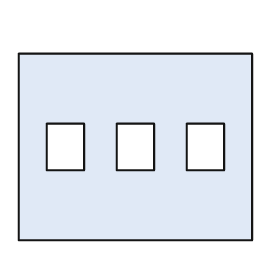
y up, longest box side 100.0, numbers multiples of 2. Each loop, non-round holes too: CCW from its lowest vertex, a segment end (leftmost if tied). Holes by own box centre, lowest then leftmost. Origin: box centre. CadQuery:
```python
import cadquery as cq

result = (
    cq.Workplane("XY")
    .moveTo(-50.0, -40.0)
    .lineTo(50.0, -40.0)
    .lineTo(50.0, 40.0)
    .lineTo(-50.0, 40.0)
    .close()
    .moveTo(-38.0, -10.0)
    .lineTo(-22.0, -10.0)
    .lineTo(-22.0, 10.0)
    .lineTo(-38.0, 10.0)
    .close()
    .moveTo(-8.0, -10.0)
    .lineTo(8.0, -10.0)
    .lineTo(8.0, 10.0)
    .lineTo(-8.0, 10.0)
    .close()
    .moveTo(22.0, -10.0)
    .lineTo(38.0, -10.0)
    .lineTo(38.0, 10.0)
    .lineTo(22.0, 10.0)
    .close()
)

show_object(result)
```